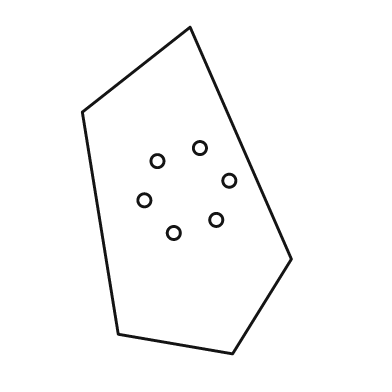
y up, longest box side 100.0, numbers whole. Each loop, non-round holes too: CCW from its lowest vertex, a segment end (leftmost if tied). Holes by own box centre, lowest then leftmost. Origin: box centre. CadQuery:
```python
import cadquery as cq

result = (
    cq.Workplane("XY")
    .moveTo(14.0, -50.0)
    .lineTo(32.0, -21.0)
    .lineTo(1.0, 50.0)
    .lineTo(-32.0, 24.0)
    .lineTo(-21.0, -44.0)
    .close()
    .moveTo(-4.0, -13.0)
    .circle(2.0)
    .moveTo(9.0, -9.0)
    .circle(2.0)
    .moveTo(-13.0, -3.0)
    .circle(2.0)
    .moveTo(13.0, 3.0)
    .circle(2.0)
    .moveTo(-9.0, 9.0)
    .circle(2.0)
    .moveTo(4.0, 13.0)
    .circle(2.0)
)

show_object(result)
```